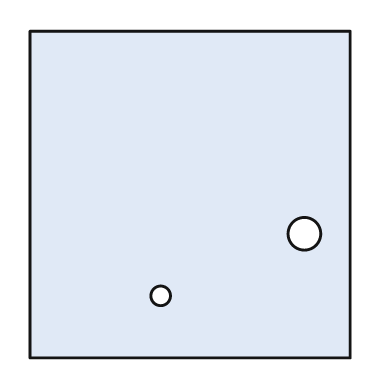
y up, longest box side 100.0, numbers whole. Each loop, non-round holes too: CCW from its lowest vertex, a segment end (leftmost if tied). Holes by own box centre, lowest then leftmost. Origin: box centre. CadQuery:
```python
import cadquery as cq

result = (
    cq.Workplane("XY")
    .moveTo(-49.0, -50.0)
    .lineTo(49.0, -50.0)
    .lineTo(49.0, 50.0)
    .lineTo(-49.0, 50.0)
    .close()
    .moveTo(-9.0, -31.0)
    .circle(3.0)
    .moveTo(35.0, -12.0)
    .circle(5.0)
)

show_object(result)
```